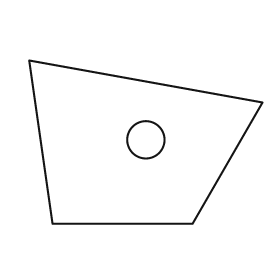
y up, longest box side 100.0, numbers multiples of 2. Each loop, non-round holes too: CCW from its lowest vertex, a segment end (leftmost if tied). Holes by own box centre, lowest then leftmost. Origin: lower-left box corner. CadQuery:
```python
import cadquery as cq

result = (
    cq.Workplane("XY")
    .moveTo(10.0, 0.0)
    .lineTo(70.0, 0.0)
    .lineTo(100.0, 52.0)
    .lineTo(0.0, 70.0)
    .close()
    .moveTo(50.0, 36.0)
    .circle(8.0)
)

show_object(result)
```